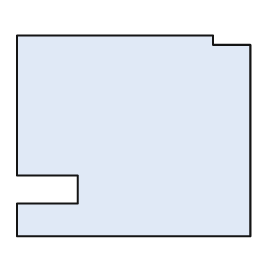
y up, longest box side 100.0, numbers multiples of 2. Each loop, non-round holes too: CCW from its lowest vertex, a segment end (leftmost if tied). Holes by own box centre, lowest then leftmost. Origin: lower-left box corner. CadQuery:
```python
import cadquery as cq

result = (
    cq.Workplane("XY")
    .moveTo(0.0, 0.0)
    .lineTo(100.0, 0.0)
    .lineTo(100.0, 82.0)
    .lineTo(84.0, 82.0)
    .lineTo(84.0, 86.0)
    .lineTo(0.0, 86.0)
    .lineTo(0.0, 26.0)
    .lineTo(26.0, 26.0)
    .lineTo(26.0, 14.0)
    .lineTo(0.0, 14.0)
    .close()
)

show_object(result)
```